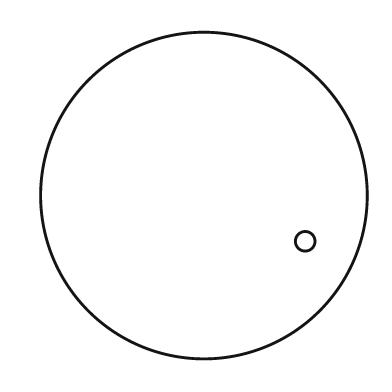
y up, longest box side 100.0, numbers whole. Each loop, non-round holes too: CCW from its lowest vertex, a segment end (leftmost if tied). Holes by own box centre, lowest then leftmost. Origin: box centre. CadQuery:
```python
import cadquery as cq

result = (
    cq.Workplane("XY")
    .moveTo(0.0, 0.0)
    .circle(50.0)
    .moveTo(31.0, -14.0)
    .circle(3.0)
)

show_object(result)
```